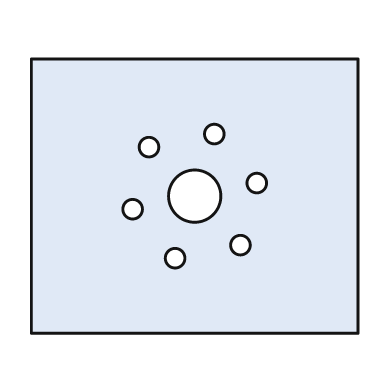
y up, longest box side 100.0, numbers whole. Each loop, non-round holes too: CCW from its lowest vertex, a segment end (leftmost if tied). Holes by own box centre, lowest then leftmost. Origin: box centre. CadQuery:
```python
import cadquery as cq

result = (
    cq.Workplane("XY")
    .moveTo(-50.0, -42.0)
    .lineTo(50.0, -42.0)
    .lineTo(50.0, 42.0)
    .lineTo(-50.0, 42.0)
    .close()
    .moveTo(-6.0, -19.0)
    .circle(3.0)
    .moveTo(14.0, -15.0)
    .circle(3.0)
    .moveTo(-19.0, -4.0)
    .circle(3.0)
    .moveTo(0.0, 0.0)
    .circle(8.0)
    .moveTo(19.0, 4.0)
    .circle(3.0)
    .moveTo(-14.0, 15.0)
    .circle(3.0)
    .moveTo(6.0, 19.0)
    .circle(3.0)
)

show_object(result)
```